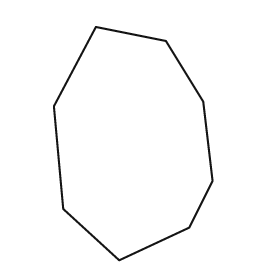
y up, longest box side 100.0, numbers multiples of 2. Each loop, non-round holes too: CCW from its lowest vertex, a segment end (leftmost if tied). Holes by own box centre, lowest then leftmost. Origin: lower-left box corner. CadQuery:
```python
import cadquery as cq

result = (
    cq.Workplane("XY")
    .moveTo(28.0, 0.0)
    .lineTo(58.0, 14.0)
    .lineTo(68.0, 34.0)
    .lineTo(64.0, 68.0)
    .lineTo(48.0, 94.0)
    .lineTo(18.0, 100.0)
    .lineTo(0.0, 66.0)
    .lineTo(4.0, 22.0)
    .close()
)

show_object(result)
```